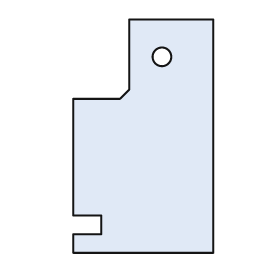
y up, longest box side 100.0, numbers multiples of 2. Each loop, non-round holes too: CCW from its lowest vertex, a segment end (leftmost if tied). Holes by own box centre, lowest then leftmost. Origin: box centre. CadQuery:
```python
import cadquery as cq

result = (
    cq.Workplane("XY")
    .moveTo(-30.0, -50.0)
    .lineTo(30.0, -50.0)
    .lineTo(30.0, 50.0)
    .lineTo(-6.0, 50.0)
    .lineTo(-6.0, 20.0)
    .lineTo(-10.0, 16.0)
    .lineTo(-30.0, 16.0)
    .lineTo(-30.0, -34.0)
    .lineTo(-18.0, -34.0)
    .lineTo(-18.0, -42.0)
    .lineTo(-30.0, -42.0)
    .close()
    .moveTo(8.0, 34.0)
    .circle(4.0)
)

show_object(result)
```